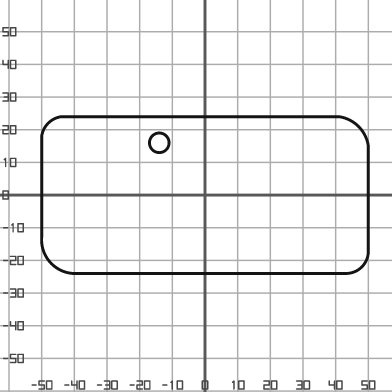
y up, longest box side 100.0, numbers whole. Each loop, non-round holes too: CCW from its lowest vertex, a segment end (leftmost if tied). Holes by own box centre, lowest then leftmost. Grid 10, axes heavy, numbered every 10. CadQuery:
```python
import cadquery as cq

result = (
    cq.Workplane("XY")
    .moveTo(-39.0, -24.0)
    .lineTo(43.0, -24.0)
    .threePointArc((48.0, -22.0), (50.0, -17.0))
    .lineTo(50.0, 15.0)
    .threePointArc((47.0, 21.0), (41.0, 24.0))
    .lineTo(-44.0, 24.0)
    .threePointArc((-48.0, 22.0), (-50.0, 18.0))
    .lineTo(-50.0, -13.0)
    .threePointArc((-47.0, -21.0), (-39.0, -24.0))
    .close()
    .moveTo(-14.0, 16.0)
    .circle(3.0)
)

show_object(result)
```